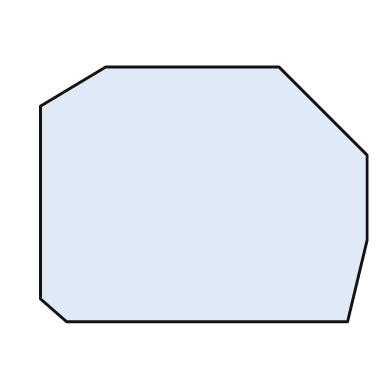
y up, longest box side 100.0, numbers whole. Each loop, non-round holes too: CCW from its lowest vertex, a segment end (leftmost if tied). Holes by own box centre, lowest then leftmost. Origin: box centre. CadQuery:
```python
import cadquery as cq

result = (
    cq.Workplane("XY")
    .moveTo(-42.0, -39.0)
    .lineTo(44.0, -39.0)
    .lineTo(50.0, -14.0)
    .lineTo(50.0, 12.0)
    .lineTo(23.0, 39.0)
    .lineTo(-30.0, 39.0)
    .lineTo(-50.0, 27.0)
    .lineTo(-50.0, -32.0)
    .close()
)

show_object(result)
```